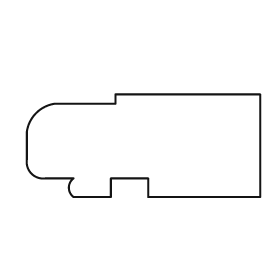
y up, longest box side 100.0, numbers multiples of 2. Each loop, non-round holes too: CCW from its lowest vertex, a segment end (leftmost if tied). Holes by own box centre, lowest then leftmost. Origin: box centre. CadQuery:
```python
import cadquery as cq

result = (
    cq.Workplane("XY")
    .moveTo(-30.0, -22.0)
    .lineTo(-14.0, -22.0)
    .lineTo(-14.0, -14.0)
    .lineTo(2.0, -14.0)
    .lineTo(2.0, -22.0)
    .lineTo(50.0, -22.0)
    .lineTo(50.0, 22.0)
    .lineTo(-12.0, 22.0)
    .lineTo(-12.0, 18.0)
    .lineTo(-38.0, 18.0)
    .threePointArc((-46.0, 14.0), (-50.0, 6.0))
    .lineTo(-50.0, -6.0)
    .threePointArc((-48.0, -12.0), (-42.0, -14.0))
    .lineTo(-30.0, -14.0)
    .threePointArc((-32.0, -18.0), (-30.0, -22.0))
    .close()
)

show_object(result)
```